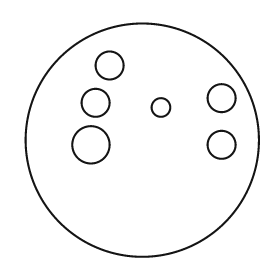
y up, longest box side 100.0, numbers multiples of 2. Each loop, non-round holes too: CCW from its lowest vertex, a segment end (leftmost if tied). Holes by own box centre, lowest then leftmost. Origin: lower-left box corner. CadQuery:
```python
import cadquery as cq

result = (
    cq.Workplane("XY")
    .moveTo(50.0, 50.0)
    .circle(50.0)
    .moveTo(28.0, 48.0)
    .circle(8.0)
    .moveTo(84.0, 48.0)
    .circle(6.0)
    .moveTo(58.0, 64.0)
    .circle(4.0)
    .moveTo(30.0, 66.0)
    .circle(6.0)
    .moveTo(84.0, 68.0)
    .circle(6.0)
    .moveTo(36.0, 82.0)
    .circle(6.0)
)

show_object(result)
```